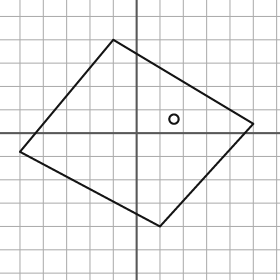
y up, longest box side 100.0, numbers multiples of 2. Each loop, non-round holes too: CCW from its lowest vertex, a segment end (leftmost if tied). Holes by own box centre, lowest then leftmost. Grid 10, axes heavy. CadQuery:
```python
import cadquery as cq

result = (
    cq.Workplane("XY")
    .moveTo(10.0, -40.0)
    .lineTo(50.0, 4.0)
    .lineTo(-10.0, 40.0)
    .lineTo(-50.0, -8.0)
    .close()
    .moveTo(16.0, 6.0)
    .circle(2.0)
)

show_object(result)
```